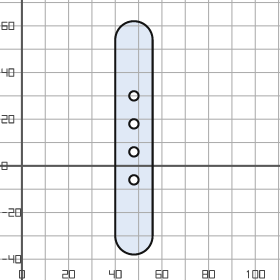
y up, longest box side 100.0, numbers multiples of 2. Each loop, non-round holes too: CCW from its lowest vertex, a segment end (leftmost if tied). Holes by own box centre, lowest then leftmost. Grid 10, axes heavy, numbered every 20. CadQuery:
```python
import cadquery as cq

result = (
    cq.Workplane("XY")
    .moveTo(40.0, -30.0)
    .threePointArc((48.0, -38.0), (56.0, -30.0))
    .lineTo(56.0, 54.0)
    .threePointArc((48.0, 62.0), (40.0, 54.0))
    .close()
    .moveTo(48.0, -6.0)
    .circle(2.0)
    .moveTo(48.0, 6.0)
    .circle(2.0)
    .moveTo(48.0, 18.0)
    .circle(2.0)
    .moveTo(48.0, 30.0)
    .circle(2.0)
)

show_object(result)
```